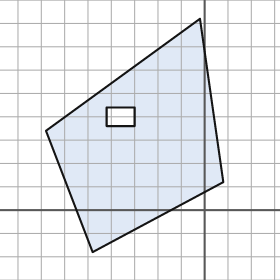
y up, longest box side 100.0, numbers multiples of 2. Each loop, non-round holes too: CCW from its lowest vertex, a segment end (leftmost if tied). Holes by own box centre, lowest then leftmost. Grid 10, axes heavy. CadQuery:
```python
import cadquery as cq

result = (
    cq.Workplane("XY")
    .moveTo(-48.0, -18.0)
    .lineTo(8.0, 12.0)
    .lineTo(-2.0, 82.0)
    .lineTo(-68.0, 34.0)
    .close()
    .moveTo(-42.0, 36.0)
    .lineTo(-30.0, 36.0)
    .lineTo(-30.0, 44.0)
    .lineTo(-42.0, 44.0)
    .close()
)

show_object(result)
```